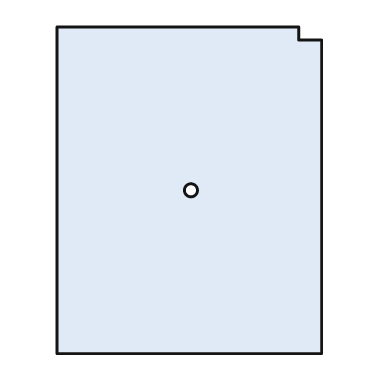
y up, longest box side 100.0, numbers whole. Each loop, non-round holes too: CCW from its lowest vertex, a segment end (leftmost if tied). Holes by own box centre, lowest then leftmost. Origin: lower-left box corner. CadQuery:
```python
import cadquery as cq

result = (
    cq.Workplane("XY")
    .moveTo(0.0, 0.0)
    .lineTo(81.0, 0.0)
    .lineTo(81.0, 96.0)
    .lineTo(74.0, 96.0)
    .lineTo(74.0, 100.0)
    .lineTo(0.0, 100.0)
    .close()
    .moveTo(41.0, 50.0)
    .circle(2.0)
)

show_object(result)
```